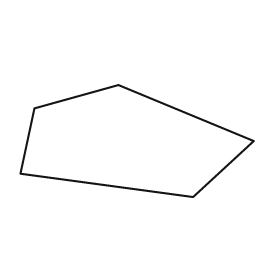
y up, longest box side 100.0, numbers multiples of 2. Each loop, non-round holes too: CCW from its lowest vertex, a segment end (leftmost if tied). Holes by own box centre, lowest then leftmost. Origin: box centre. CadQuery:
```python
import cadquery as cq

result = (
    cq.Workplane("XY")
    .moveTo(24.0, -24.0)
    .lineTo(50.0, 0.0)
    .lineTo(-8.0, 24.0)
    .lineTo(-44.0, 14.0)
    .lineTo(-50.0, -14.0)
    .close()
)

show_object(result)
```